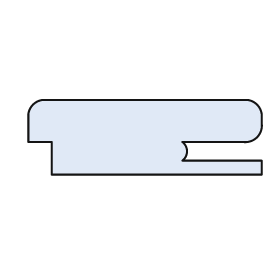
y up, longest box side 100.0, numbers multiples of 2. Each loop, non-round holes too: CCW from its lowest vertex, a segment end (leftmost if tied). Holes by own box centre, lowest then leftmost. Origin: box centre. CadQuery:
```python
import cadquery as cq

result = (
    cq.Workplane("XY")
    .moveTo(-40.0, -16.0)
    .lineTo(50.0, -16.0)
    .lineTo(50.0, -10.0)
    .lineTo(16.0, -10.0)
    .threePointArc((18.0, -6.0), (16.0, -2.0))
    .lineTo(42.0, -2.0)
    .threePointArc((48.0, 0.0), (50.0, 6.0))
    .lineTo(50.0, 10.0)
    .threePointArc((48.0, 14.0), (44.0, 16.0))
    .lineTo(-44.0, 16.0)
    .threePointArc((-48.0, 14.0), (-50.0, 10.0))
    .lineTo(-50.0, -2.0)
    .lineTo(-40.0, -2.0)
    .close()
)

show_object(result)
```